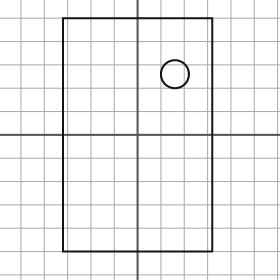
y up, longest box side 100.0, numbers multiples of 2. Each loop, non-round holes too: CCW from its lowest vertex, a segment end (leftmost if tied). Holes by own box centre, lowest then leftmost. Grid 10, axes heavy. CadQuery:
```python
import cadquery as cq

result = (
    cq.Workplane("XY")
    .moveTo(-32.0, -50.0)
    .lineTo(32.0, -50.0)
    .lineTo(32.0, 50.0)
    .lineTo(-32.0, 50.0)
    .close()
    .moveTo(16.0, 26.0)
    .circle(6.0)
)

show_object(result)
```